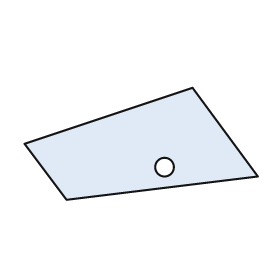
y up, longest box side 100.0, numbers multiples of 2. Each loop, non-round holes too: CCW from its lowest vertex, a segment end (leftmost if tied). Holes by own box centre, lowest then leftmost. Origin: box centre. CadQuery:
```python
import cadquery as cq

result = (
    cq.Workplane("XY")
    .moveTo(-32.0, -24.0)
    .lineTo(50.0, -14.0)
    .lineTo(22.0, 24.0)
    .lineTo(-50.0, 0.0)
    .close()
    .moveTo(10.0, -10.0)
    .circle(4.0)
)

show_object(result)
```